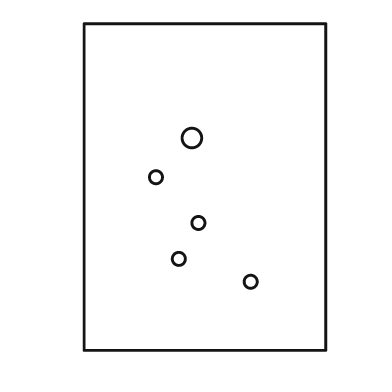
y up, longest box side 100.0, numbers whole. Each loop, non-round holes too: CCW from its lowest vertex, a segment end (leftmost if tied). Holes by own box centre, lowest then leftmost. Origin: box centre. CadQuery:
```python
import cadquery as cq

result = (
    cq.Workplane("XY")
    .moveTo(-37.0, -50.0)
    .lineTo(37.0, -50.0)
    .lineTo(37.0, 50.0)
    .lineTo(-37.0, 50.0)
    .close()
    .moveTo(14.0, -29.0)
    .circle(2.0)
    .moveTo(-8.0, -22.0)
    .circle(2.0)
    .moveTo(-2.0, -11.0)
    .circle(2.0)
    .moveTo(-15.0, 3.0)
    .circle(2.0)
    .moveTo(-4.0, 15.0)
    .circle(3.0)
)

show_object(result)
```